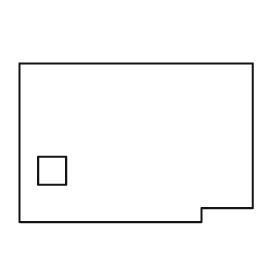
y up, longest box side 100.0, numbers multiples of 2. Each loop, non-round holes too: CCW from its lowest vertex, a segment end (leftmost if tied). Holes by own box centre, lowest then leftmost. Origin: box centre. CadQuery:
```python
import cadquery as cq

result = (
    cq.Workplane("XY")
    .moveTo(-50.0, -34.0)
    .lineTo(28.0, -34.0)
    .lineTo(28.0, -28.0)
    .lineTo(50.0, -28.0)
    .lineTo(50.0, 34.0)
    .lineTo(-50.0, 34.0)
    .close()
    .moveTo(-42.0, -18.0)
    .lineTo(-30.0, -18.0)
    .lineTo(-30.0, -6.0)
    .lineTo(-42.0, -6.0)
    .close()
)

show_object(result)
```